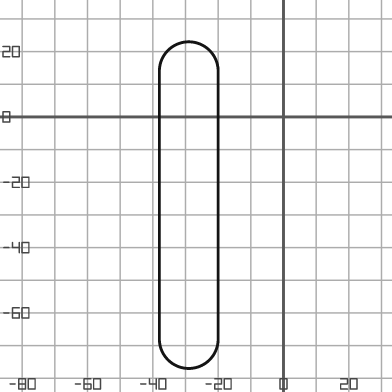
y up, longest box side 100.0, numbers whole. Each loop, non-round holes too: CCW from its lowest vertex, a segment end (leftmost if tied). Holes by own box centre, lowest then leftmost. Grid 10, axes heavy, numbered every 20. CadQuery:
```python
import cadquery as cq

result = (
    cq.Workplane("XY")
    .moveTo(-38.0, -68.0)
    .threePointArc((-29.0, -77.0), (-20.0, -68.0))
    .lineTo(-20.0, 14.0)
    .threePointArc((-29.0, 23.0), (-38.0, 14.0))
    .close()
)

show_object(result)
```